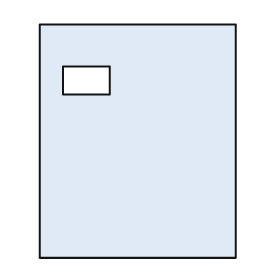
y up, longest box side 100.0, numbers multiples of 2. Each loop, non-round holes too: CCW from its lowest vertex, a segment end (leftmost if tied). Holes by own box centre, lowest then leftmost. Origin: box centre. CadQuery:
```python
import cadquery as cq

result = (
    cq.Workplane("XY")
    .moveTo(-42.0, -50.0)
    .lineTo(42.0, -50.0)
    .lineTo(42.0, 50.0)
    .lineTo(-42.0, 50.0)
    .close()
    .moveTo(-32.0, 20.0)
    .lineTo(-12.0, 20.0)
    .lineTo(-12.0, 32.0)
    .lineTo(-32.0, 32.0)
    .close()
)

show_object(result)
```